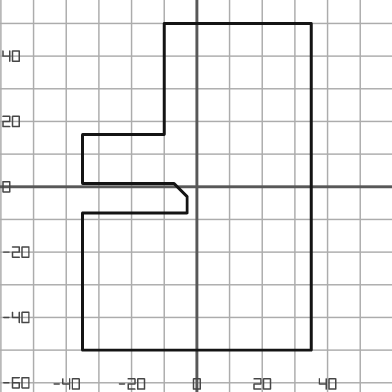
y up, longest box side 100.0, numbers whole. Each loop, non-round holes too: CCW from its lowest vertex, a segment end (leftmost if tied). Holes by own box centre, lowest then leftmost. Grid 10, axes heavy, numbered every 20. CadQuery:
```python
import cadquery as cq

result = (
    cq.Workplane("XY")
    .moveTo(-35.0, -50.0)
    .lineTo(35.0, -50.0)
    .lineTo(35.0, 50.0)
    .lineTo(-10.0, 50.0)
    .lineTo(-10.0, 16.0)
    .lineTo(-35.0, 16.0)
    .lineTo(-35.0, 1.0)
    .lineTo(-7.0, 1.0)
    .lineTo(-3.0, -3.0)
    .lineTo(-3.0, -8.0)
    .lineTo(-35.0, -8.0)
    .close()
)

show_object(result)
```